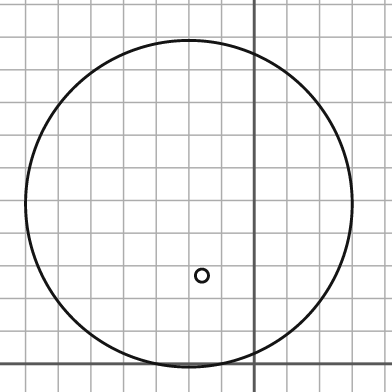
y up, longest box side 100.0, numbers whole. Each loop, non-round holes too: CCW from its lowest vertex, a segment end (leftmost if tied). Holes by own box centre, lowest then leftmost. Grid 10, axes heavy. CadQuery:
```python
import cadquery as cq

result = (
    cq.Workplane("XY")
    .moveTo(-20.0, 49.0)
    .circle(50.0)
    .moveTo(-16.0, 27.0)
    .circle(2.0)
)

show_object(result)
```